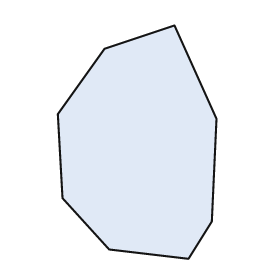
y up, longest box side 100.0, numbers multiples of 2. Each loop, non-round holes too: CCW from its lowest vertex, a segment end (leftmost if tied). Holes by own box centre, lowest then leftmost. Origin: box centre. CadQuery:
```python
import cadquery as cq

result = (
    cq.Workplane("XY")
    .moveTo(22.0, -50.0)
    .lineTo(32.0, -34.0)
    .lineTo(34.0, 10.0)
    .lineTo(16.0, 50.0)
    .lineTo(-14.0, 40.0)
    .lineTo(-34.0, 12.0)
    .lineTo(-32.0, -24.0)
    .lineTo(-12.0, -46.0)
    .close()
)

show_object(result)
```